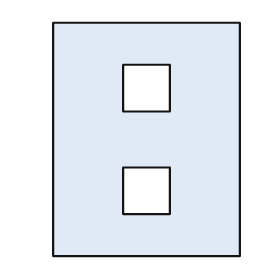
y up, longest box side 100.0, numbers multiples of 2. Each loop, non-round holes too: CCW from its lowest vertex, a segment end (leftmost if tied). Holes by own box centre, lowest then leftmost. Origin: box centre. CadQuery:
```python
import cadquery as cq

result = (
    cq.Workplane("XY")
    .moveTo(-40.0, -50.0)
    .lineTo(40.0, -50.0)
    .lineTo(40.0, 50.0)
    .lineTo(-40.0, 50.0)
    .close()
    .moveTo(-10.0, -32.0)
    .lineTo(10.0, -32.0)
    .lineTo(10.0, -12.0)
    .lineTo(-10.0, -12.0)
    .close()
    .moveTo(-10.0, 12.0)
    .lineTo(10.0, 12.0)
    .lineTo(10.0, 32.0)
    .lineTo(-10.0, 32.0)
    .close()
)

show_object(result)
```